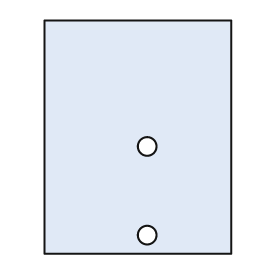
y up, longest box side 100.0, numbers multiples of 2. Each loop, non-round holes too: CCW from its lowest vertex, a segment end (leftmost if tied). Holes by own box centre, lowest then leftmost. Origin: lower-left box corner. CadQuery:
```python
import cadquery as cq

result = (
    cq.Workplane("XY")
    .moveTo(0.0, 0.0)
    .lineTo(80.0, 0.0)
    .lineTo(80.0, 100.0)
    .lineTo(0.0, 100.0)
    .close()
    .moveTo(44.0, 8.0)
    .circle(4.0)
    .moveTo(44.0, 46.0)
    .circle(4.0)
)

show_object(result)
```